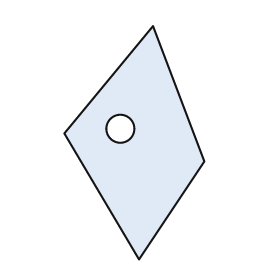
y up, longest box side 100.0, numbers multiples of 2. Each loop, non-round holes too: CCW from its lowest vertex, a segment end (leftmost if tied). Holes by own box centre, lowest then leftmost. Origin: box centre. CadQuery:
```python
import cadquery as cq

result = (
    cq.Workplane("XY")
    .moveTo(2.0, -50.0)
    .lineTo(30.0, -8.0)
    .lineTo(8.0, 50.0)
    .lineTo(-30.0, 4.0)
    .close()
    .moveTo(-6.0, 6.0)
    .circle(6.0)
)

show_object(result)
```